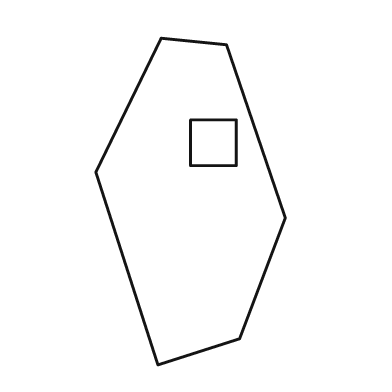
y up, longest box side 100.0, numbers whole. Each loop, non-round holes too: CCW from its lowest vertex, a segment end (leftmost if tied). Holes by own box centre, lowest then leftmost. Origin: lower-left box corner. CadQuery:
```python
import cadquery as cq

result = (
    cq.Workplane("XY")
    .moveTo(19.0, 0.0)
    .lineTo(44.0, 8.0)
    .lineTo(58.0, 45.0)
    .lineTo(40.0, 98.0)
    .lineTo(20.0, 100.0)
    .lineTo(0.0, 59.0)
    .close()
    .moveTo(29.0, 61.0)
    .lineTo(43.0, 61.0)
    .lineTo(43.0, 75.0)
    .lineTo(29.0, 75.0)
    .close()
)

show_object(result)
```